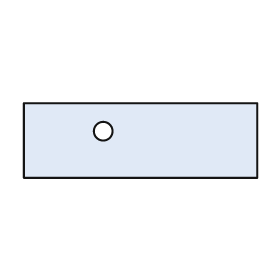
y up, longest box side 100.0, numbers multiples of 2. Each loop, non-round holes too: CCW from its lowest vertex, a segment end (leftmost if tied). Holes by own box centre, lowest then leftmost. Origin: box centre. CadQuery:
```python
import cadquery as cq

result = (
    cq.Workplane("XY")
    .moveTo(-50.0, -16.0)
    .lineTo(50.0, -16.0)
    .lineTo(50.0, 16.0)
    .lineTo(-50.0, 16.0)
    .close()
    .moveTo(-16.0, 4.0)
    .circle(4.0)
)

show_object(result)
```